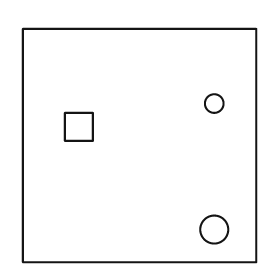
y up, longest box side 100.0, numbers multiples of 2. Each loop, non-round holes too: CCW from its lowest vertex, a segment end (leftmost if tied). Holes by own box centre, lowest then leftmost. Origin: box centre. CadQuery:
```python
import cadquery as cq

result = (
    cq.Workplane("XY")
    .moveTo(-50.0, -50.0)
    .lineTo(50.0, -50.0)
    .lineTo(50.0, 50.0)
    .lineTo(-50.0, 50.0)
    .close()
    .moveTo(32.0, -36.0)
    .circle(6.0)
    .moveTo(-32.0, 2.0)
    .lineTo(-20.0, 2.0)
    .lineTo(-20.0, 14.0)
    .lineTo(-32.0, 14.0)
    .close()
    .moveTo(32.0, 18.0)
    .circle(4.0)
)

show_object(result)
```